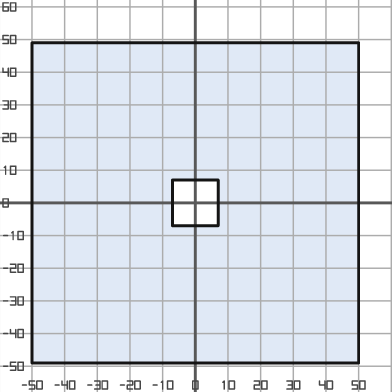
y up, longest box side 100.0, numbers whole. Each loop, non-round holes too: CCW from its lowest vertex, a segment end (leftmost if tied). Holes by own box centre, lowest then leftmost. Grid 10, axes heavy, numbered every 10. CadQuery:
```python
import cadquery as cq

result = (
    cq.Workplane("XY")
    .moveTo(-50.0, -49.0)
    .lineTo(50.0, -49.0)
    .lineTo(50.0, 49.0)
    .lineTo(-50.0, 49.0)
    .close()
    .moveTo(-7.0, -7.0)
    .lineTo(7.0, -7.0)
    .lineTo(7.0, 7.0)
    .lineTo(-7.0, 7.0)
    .close()
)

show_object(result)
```